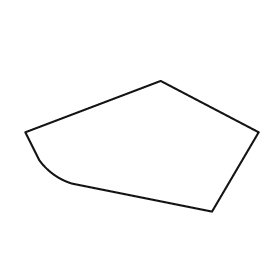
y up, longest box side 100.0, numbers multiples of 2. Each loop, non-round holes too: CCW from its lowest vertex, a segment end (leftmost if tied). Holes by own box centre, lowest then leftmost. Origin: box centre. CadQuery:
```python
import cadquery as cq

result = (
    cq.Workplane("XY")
    .moveTo(30.0, -28.0)
    .lineTo(50.0, 6.0)
    .lineTo(8.0, 28.0)
    .lineTo(-50.0, 6.0)
    .lineTo(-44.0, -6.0)
    .threePointArc((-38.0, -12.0), (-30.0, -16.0))
    .close()
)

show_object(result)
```